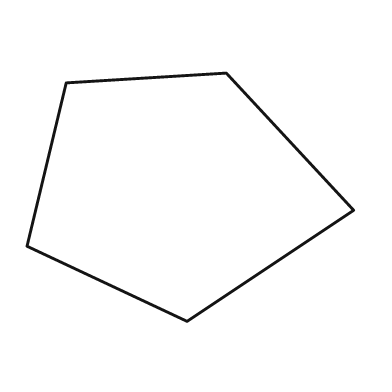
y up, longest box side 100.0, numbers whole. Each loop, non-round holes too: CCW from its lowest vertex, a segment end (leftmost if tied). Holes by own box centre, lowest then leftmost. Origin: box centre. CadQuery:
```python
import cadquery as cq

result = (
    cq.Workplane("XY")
    .moveTo(-1.0, -38.0)
    .lineTo(50.0, -4.0)
    .lineTo(11.0, 38.0)
    .lineTo(-38.0, 35.0)
    .lineTo(-50.0, -15.0)
    .close()
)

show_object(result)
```